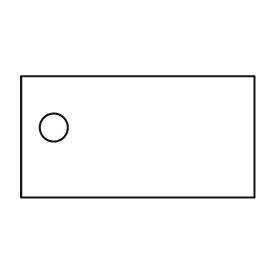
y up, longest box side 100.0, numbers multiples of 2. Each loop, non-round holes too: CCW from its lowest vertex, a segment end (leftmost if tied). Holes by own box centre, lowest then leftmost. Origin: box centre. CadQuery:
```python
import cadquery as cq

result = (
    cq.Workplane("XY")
    .moveTo(-50.0, -26.0)
    .lineTo(50.0, -26.0)
    .lineTo(50.0, 26.0)
    .lineTo(-50.0, 26.0)
    .close()
    .moveTo(-36.0, 4.0)
    .circle(6.0)
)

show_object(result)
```